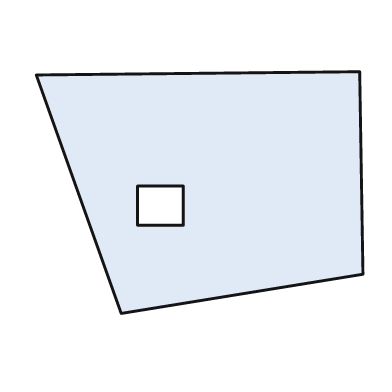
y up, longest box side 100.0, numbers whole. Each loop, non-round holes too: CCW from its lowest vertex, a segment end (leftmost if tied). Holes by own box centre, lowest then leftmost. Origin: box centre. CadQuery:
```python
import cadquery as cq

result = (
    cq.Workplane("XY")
    .moveTo(-24.0, -37.0)
    .lineTo(50.0, -25.0)
    .lineTo(49.0, 37.0)
    .lineTo(-50.0, 36.0)
    .close()
    .moveTo(-19.0, -10.0)
    .lineTo(-5.0, -10.0)
    .lineTo(-5.0, 2.0)
    .lineTo(-19.0, 2.0)
    .close()
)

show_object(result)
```